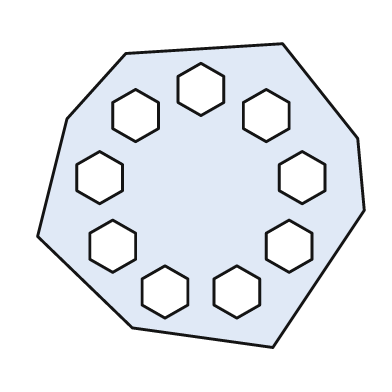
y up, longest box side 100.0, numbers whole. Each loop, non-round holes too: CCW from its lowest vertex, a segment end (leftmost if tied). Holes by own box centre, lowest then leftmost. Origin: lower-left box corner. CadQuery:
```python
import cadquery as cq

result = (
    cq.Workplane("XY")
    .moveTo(72.0, 0.0)
    .lineTo(100.0, 42.0)
    .lineTo(98.0, 64.0)
    .lineTo(75.0, 93.0)
    .lineTo(27.0, 90.0)
    .lineTo(9.0, 70.0)
    .lineTo(0.0, 34.0)
    .lineTo(29.0, 6.0)
    .close()
    .moveTo(39.0, 9.0)
    .lineTo(46.0, 13.0)
    .lineTo(46.0, 21.0)
    .lineTo(39.0, 25.0)
    .lineTo(32.0, 21.0)
    .lineTo(32.0, 13.0)
    .close()
    .moveTo(61.0, 9.0)
    .lineTo(68.0, 13.0)
    .lineTo(68.0, 21.0)
    .lineTo(61.0, 25.0)
    .lineTo(54.0, 21.0)
    .lineTo(54.0, 13.0)
    .close()
    .moveTo(23.0, 23.0)
    .lineTo(30.0, 27.0)
    .lineTo(30.0, 35.0)
    .lineTo(23.0, 39.0)
    .lineTo(16.0, 35.0)
    .lineTo(16.0, 27.0)
    .close()
    .moveTo(77.0, 23.0)
    .lineTo(84.0, 27.0)
    .lineTo(84.0, 35.0)
    .lineTo(77.0, 39.0)
    .lineTo(70.0, 35.0)
    .lineTo(70.0, 27.0)
    .close()
    .moveTo(19.0, 44.0)
    .lineTo(26.0, 48.0)
    .lineTo(26.0, 56.0)
    .lineTo(19.0, 60.0)
    .lineTo(12.0, 56.0)
    .lineTo(12.0, 48.0)
    .close()
    .moveTo(81.0, 44.0)
    .lineTo(88.0, 48.0)
    .lineTo(88.0, 56.0)
    .lineTo(81.0, 60.0)
    .lineTo(74.0, 56.0)
    .lineTo(74.0, 48.0)
    .close()
    .moveTo(30.0, 63.0)
    .lineTo(37.0, 67.0)
    .lineTo(37.0, 75.0)
    .lineTo(30.0, 79.0)
    .lineTo(23.0, 75.0)
    .lineTo(23.0, 67.0)
    .close()
    .moveTo(70.0, 63.0)
    .lineTo(77.0, 67.0)
    .lineTo(77.0, 75.0)
    .lineTo(70.0, 79.0)
    .lineTo(63.0, 75.0)
    .lineTo(63.0, 67.0)
    .close()
    .moveTo(50.0, 71.0)
    .lineTo(57.0, 75.0)
    .lineTo(57.0, 83.0)
    .lineTo(50.0, 87.0)
    .lineTo(43.0, 83.0)
    .lineTo(43.0, 75.0)
    .close()
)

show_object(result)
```